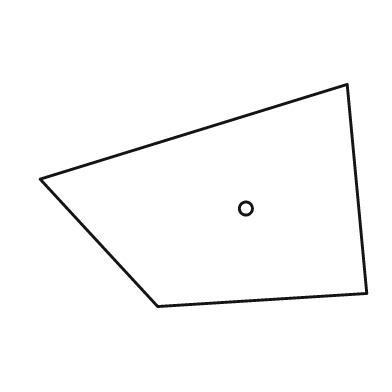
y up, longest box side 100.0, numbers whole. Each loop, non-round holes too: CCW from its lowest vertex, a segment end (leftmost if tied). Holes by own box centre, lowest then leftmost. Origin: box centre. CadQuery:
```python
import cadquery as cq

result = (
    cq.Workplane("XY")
    .moveTo(-14.0, -34.0)
    .lineTo(50.0, -30.0)
    .lineTo(44.0, 34.0)
    .lineTo(-50.0, 5.0)
    .close()
    .moveTo(13.0, -4.0)
    .circle(2.0)
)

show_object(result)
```